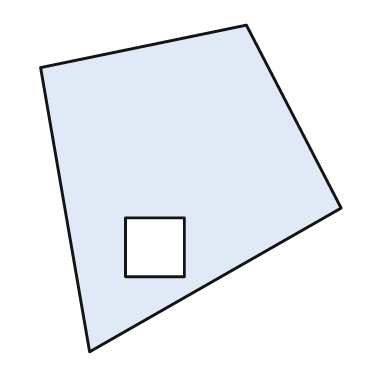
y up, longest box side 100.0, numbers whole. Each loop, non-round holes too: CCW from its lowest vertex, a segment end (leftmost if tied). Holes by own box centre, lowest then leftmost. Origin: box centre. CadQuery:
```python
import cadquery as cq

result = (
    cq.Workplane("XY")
    .moveTo(-31.0, -50.0)
    .lineTo(46.0, -6.0)
    .lineTo(17.0, 50.0)
    .lineTo(-46.0, 37.0)
    .close()
    .moveTo(-20.0, -27.0)
    .lineTo(-2.0, -27.0)
    .lineTo(-2.0, -9.0)
    .lineTo(-20.0, -9.0)
    .close()
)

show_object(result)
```